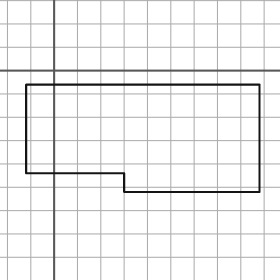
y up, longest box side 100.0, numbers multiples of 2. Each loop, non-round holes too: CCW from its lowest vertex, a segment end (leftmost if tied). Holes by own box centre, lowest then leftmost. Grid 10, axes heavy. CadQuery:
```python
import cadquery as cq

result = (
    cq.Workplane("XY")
    .moveTo(30.0, -52.0)
    .lineTo(88.0, -52.0)
    .lineTo(88.0, -6.0)
    .lineTo(-12.0, -6.0)
    .lineTo(-12.0, -44.0)
    .lineTo(30.0, -44.0)
    .close()
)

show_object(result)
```